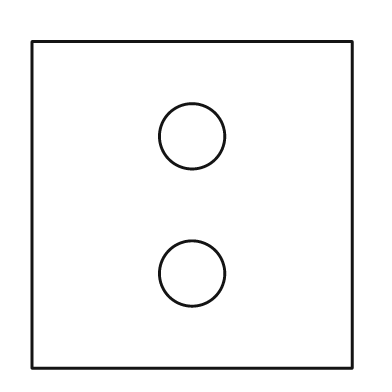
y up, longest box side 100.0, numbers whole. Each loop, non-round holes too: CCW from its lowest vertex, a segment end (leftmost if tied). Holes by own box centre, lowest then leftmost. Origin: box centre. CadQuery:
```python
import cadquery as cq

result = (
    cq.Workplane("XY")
    .moveTo(-49.0, -50.0)
    .lineTo(49.0, -50.0)
    .lineTo(49.0, 50.0)
    .lineTo(-49.0, 50.0)
    .close()
    .moveTo(0.0, -21.0)
    .circle(10.0)
    .moveTo(0.0, 21.0)
    .circle(10.0)
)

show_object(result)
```